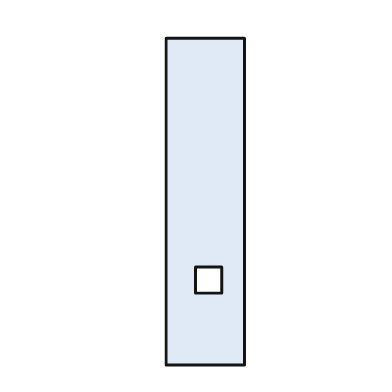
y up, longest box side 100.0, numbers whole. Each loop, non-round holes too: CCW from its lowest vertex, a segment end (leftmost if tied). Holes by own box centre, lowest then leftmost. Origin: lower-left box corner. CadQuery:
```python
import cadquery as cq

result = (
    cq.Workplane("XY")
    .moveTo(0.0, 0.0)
    .lineTo(24.0, 0.0)
    .lineTo(24.0, 100.0)
    .lineTo(0.0, 100.0)
    .close()
    .moveTo(9.0, 22.0)
    .lineTo(17.0, 22.0)
    .lineTo(17.0, 30.0)
    .lineTo(9.0, 30.0)
    .close()
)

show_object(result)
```